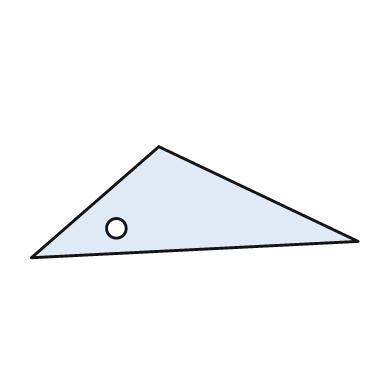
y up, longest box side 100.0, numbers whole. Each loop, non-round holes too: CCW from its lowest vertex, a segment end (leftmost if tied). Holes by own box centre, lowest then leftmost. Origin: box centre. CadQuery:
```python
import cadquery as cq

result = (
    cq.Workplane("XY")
    .moveTo(-50.0, -17.0)
    .lineTo(50.0, -12.0)
    .lineTo(-11.0, 17.0)
    .close()
    .moveTo(-24.0, -8.0)
    .circle(3.0)
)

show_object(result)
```